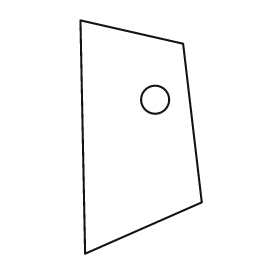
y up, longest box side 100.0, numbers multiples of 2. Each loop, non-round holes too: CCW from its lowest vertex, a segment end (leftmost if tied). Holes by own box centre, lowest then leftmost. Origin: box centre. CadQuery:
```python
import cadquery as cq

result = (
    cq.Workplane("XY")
    .moveTo(-24.0, -50.0)
    .lineTo(26.0, -28.0)
    .lineTo(18.0, 40.0)
    .lineTo(-26.0, 50.0)
    .close()
    .moveTo(6.0, 16.0)
    .circle(6.0)
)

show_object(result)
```